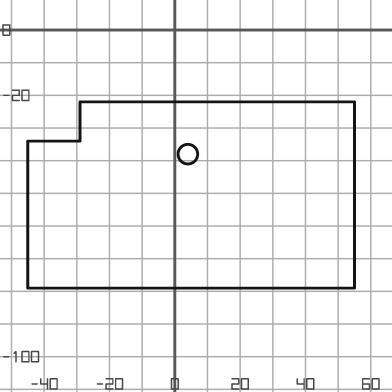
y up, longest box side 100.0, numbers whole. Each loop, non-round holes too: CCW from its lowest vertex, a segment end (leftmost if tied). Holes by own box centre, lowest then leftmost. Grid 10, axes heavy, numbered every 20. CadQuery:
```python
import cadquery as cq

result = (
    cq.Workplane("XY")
    .moveTo(-45.0, -79.0)
    .lineTo(55.0, -79.0)
    .lineTo(55.0, -22.0)
    .lineTo(-29.0, -22.0)
    .lineTo(-29.0, -34.0)
    .lineTo(-45.0, -34.0)
    .close()
    .moveTo(4.0, -38.0)
    .circle(3.0)
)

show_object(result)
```